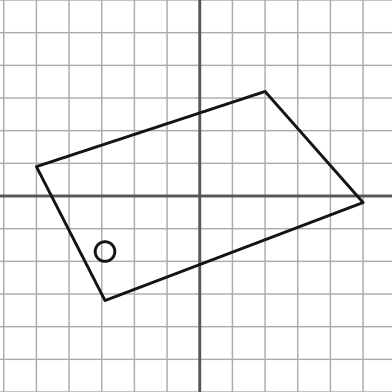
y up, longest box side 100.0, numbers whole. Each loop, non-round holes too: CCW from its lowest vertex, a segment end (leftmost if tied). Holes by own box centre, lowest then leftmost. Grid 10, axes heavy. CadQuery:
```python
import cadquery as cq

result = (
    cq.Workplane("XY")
    .moveTo(-29.0, -32.0)
    .lineTo(50.0, -2.0)
    .lineTo(20.0, 32.0)
    .lineTo(-50.0, 9.0)
    .close()
    .moveTo(-29.0, -17.0)
    .circle(3.0)
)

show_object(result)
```